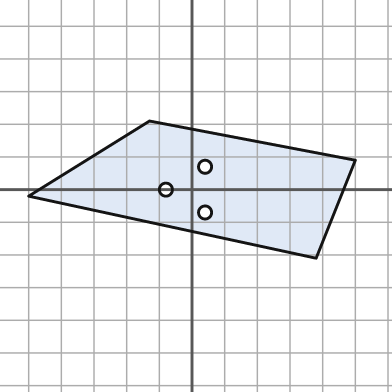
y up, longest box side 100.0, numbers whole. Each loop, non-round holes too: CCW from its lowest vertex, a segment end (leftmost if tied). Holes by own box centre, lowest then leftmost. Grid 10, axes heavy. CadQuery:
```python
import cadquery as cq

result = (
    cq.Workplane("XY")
    .moveTo(38.0, -21.0)
    .lineTo(50.0, 9.0)
    .lineTo(-13.0, 21.0)
    .lineTo(-50.0, -2.0)
    .close()
    .moveTo(4.0, -7.0)
    .circle(2.0)
    .moveTo(-8.0, 0.0)
    .circle(2.0)
    .moveTo(4.0, 7.0)
    .circle(2.0)
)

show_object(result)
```